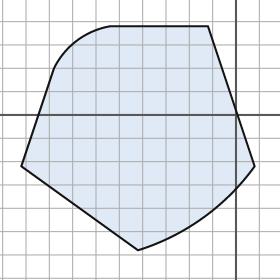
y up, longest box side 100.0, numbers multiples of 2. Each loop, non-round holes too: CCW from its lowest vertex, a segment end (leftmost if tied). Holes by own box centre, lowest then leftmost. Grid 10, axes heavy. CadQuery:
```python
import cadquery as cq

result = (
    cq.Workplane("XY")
    .moveTo(-42.0, -58.0)
    .threePointArc((-14.0, -44.0), (8.0, -22.0))
    .lineTo(-12.0, 38.0)
    .lineTo(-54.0, 38.0)
    .threePointArc((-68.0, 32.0), (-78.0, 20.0))
    .lineTo(-92.0, -22.0)
    .close()
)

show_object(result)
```